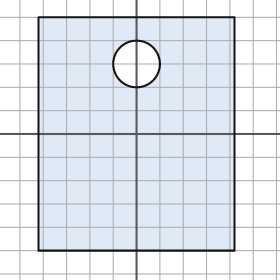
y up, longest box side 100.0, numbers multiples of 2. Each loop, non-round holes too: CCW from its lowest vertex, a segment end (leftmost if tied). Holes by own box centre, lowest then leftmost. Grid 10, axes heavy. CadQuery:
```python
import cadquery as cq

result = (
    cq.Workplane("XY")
    .moveTo(-42.0, -50.0)
    .lineTo(42.0, -50.0)
    .lineTo(42.0, 50.0)
    .lineTo(-42.0, 50.0)
    .close()
    .moveTo(0.0, 30.0)
    .circle(10.0)
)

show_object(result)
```